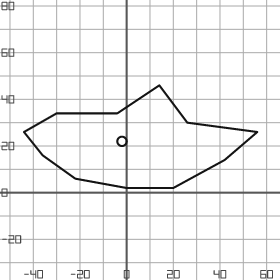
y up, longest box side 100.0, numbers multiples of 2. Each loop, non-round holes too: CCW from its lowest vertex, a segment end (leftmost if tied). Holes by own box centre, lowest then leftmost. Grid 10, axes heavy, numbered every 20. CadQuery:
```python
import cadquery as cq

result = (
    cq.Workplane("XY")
    .moveTo(0.0, 2.0)
    .lineTo(20.0, 2.0)
    .lineTo(42.0, 14.0)
    .lineTo(56.0, 26.0)
    .lineTo(26.0, 30.0)
    .lineTo(14.0, 46.0)
    .lineTo(-4.0, 34.0)
    .lineTo(-30.0, 34.0)
    .lineTo(-44.0, 26.0)
    .lineTo(-36.0, 16.0)
    .lineTo(-22.0, 6.0)
    .close()
    .moveTo(-2.0, 22.0)
    .circle(2.0)
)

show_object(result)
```